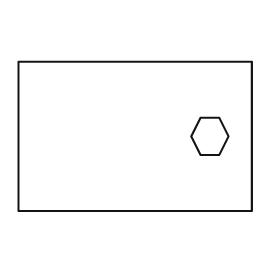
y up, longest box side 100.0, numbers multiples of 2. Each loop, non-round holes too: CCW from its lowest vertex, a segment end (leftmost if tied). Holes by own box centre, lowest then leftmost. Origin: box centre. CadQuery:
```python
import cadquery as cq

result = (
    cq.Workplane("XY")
    .moveTo(-50.0, -32.0)
    .lineTo(50.0, -32.0)
    .lineTo(50.0, 32.0)
    .lineTo(-50.0, 32.0)
    .close()
    .moveTo(28.0, -8.0)
    .lineTo(36.0, -8.0)
    .lineTo(40.0, 0.0)
    .lineTo(36.0, 8.0)
    .lineTo(28.0, 8.0)
    .lineTo(24.0, 0.0)
    .close()
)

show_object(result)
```